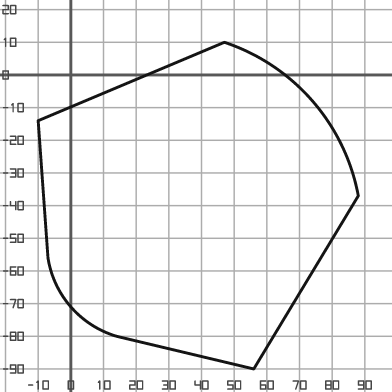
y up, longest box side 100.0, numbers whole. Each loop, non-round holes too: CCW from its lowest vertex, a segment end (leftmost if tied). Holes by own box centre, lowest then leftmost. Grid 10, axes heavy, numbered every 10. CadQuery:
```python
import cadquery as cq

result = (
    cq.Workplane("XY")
    .moveTo(56.0, -90.0)
    .lineTo(88.0, -37.0)
    .threePointArc((74.0, -8.0), (47.0, 10.0))
    .lineTo(-10.0, -14.0)
    .lineTo(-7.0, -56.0)
    .threePointArc((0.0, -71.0), (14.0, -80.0))
    .close()
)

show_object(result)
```